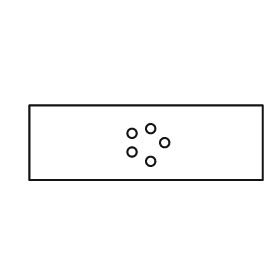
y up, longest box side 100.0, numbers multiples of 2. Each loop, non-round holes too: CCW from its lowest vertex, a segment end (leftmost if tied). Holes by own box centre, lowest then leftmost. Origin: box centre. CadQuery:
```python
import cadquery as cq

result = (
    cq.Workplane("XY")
    .moveTo(-50.0, -16.0)
    .lineTo(50.0, -16.0)
    .lineTo(50.0, 16.0)
    .lineTo(-50.0, 16.0)
    .close()
    .moveTo(2.0, -8.0)
    .circle(2.0)
    .moveTo(-6.0, -4.0)
    .circle(2.0)
    .moveTo(8.0, 0.0)
    .circle(2.0)
    .moveTo(-6.0, 4.0)
    .circle(2.0)
    .moveTo(2.0, 6.0)
    .circle(2.0)
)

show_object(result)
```